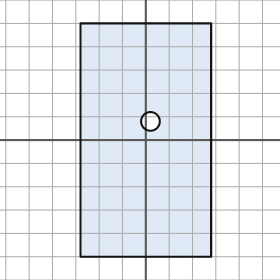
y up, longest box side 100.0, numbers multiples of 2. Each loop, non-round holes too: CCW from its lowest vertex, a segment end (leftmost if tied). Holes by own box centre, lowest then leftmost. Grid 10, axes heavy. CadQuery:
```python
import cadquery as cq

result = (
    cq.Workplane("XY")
    .moveTo(-28.0, -50.0)
    .lineTo(28.0, -50.0)
    .lineTo(28.0, 50.0)
    .lineTo(-28.0, 50.0)
    .close()
    .moveTo(2.0, 8.0)
    .circle(4.0)
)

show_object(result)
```